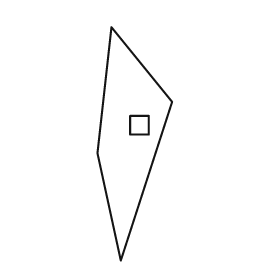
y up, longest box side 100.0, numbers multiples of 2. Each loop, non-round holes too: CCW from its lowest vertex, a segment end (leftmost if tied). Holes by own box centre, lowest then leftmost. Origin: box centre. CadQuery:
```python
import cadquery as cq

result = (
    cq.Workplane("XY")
    .moveTo(-6.0, -50.0)
    .lineTo(16.0, 18.0)
    .lineTo(-10.0, 50.0)
    .lineTo(-16.0, -4.0)
    .close()
    .moveTo(-2.0, 4.0)
    .lineTo(6.0, 4.0)
    .lineTo(6.0, 12.0)
    .lineTo(-2.0, 12.0)
    .close()
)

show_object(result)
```